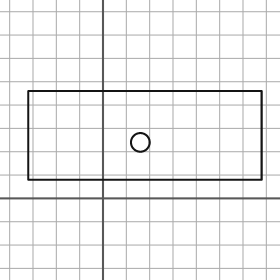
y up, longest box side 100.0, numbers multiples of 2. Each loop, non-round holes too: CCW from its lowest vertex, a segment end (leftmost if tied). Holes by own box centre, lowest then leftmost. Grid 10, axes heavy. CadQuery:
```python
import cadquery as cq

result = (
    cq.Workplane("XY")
    .moveTo(-32.0, 8.0)
    .lineTo(68.0, 8.0)
    .lineTo(68.0, 46.0)
    .lineTo(-32.0, 46.0)
    .close()
    .moveTo(16.0, 24.0)
    .circle(4.0)
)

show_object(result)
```